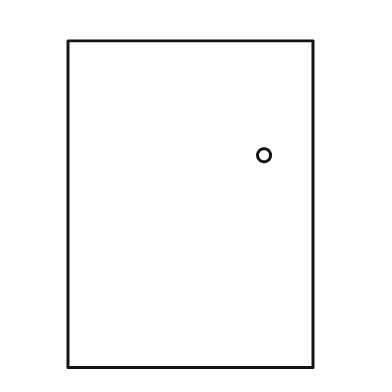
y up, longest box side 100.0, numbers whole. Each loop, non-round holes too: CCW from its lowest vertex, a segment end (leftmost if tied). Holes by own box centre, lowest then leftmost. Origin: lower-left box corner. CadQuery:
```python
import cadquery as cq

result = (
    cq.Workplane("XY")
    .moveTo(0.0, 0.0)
    .lineTo(75.0, 0.0)
    .lineTo(75.0, 100.0)
    .lineTo(0.0, 100.0)
    .close()
    .moveTo(60.0, 65.0)
    .circle(2.0)
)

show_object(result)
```